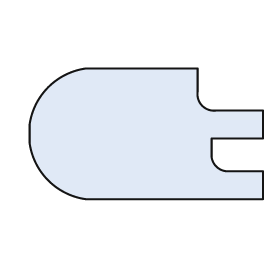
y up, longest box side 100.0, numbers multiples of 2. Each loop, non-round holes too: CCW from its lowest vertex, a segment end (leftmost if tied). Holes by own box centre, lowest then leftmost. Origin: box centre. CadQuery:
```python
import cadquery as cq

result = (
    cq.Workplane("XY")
    .moveTo(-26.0, -28.0)
    .lineTo(50.0, -28.0)
    .lineTo(50.0, -16.0)
    .lineTo(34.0, -16.0)
    .threePointArc((30.0, -14.0), (28.0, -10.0))
    .lineTo(28.0, -2.0)
    .lineTo(50.0, -2.0)
    .lineTo(50.0, 10.0)
    .lineTo(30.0, 10.0)
    .threePointArc((24.0, 12.0), (22.0, 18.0))
    .lineTo(22.0, 28.0)
    .lineTo(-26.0, 28.0)
    .threePointArc((-42.0, 20.0), (-50.0, 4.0))
    .lineTo(-50.0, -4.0)
    .threePointArc((-42.0, -20.0), (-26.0, -28.0))
    .close()
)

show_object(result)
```